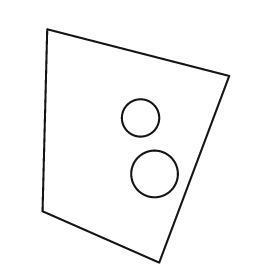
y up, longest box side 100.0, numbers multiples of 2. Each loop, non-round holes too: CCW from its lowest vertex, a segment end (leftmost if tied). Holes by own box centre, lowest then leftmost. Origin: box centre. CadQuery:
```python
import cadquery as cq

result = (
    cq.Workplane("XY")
    .moveTo(10.0, -50.0)
    .lineTo(40.0, 30.0)
    .lineTo(-38.0, 50.0)
    .lineTo(-40.0, -28.0)
    .close()
    .moveTo(8.0, -12.0)
    .circle(10.0)
    .moveTo(2.0, 12.0)
    .circle(8.0)
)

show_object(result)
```